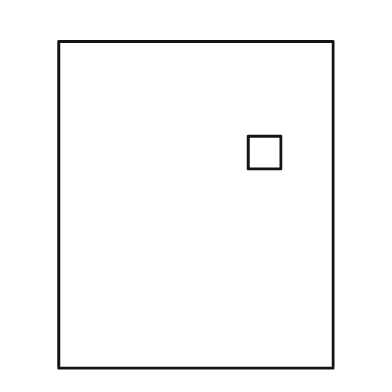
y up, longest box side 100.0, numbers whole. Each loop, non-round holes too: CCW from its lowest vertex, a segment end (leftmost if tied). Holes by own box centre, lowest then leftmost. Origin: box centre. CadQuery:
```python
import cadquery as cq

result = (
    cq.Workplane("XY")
    .moveTo(-42.0, -50.0)
    .lineTo(42.0, -50.0)
    .lineTo(42.0, 50.0)
    .lineTo(-42.0, 50.0)
    .close()
    .moveTo(16.0, 11.0)
    .lineTo(26.0, 11.0)
    .lineTo(26.0, 21.0)
    .lineTo(16.0, 21.0)
    .close()
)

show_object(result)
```